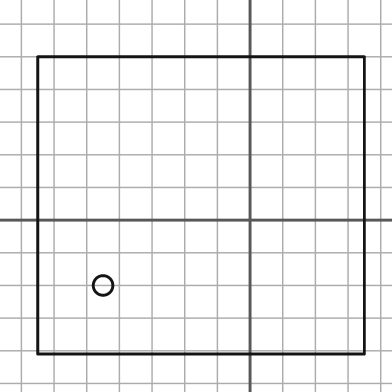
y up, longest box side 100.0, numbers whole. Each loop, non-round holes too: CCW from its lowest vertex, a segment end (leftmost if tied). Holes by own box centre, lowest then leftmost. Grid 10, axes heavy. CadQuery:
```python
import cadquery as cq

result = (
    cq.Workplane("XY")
    .moveTo(-65.0, -41.0)
    .lineTo(35.0, -41.0)
    .lineTo(35.0, 50.0)
    .lineTo(-65.0, 50.0)
    .close()
    .moveTo(-45.0, -20.0)
    .circle(3.0)
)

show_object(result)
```